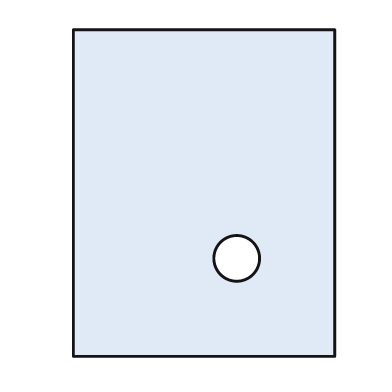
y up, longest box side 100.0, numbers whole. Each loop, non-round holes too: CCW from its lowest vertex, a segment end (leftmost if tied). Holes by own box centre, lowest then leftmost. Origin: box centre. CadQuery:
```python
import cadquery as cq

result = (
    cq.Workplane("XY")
    .moveTo(-40.0, -50.0)
    .lineTo(40.0, -50.0)
    .lineTo(40.0, 50.0)
    .lineTo(-40.0, 50.0)
    .close()
    .moveTo(10.0, -20.0)
    .circle(7.0)
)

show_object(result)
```